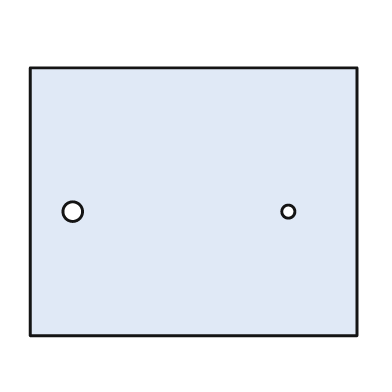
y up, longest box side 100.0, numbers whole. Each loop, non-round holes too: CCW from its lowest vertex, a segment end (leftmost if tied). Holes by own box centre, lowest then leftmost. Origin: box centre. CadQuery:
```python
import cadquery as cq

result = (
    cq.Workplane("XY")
    .moveTo(-50.0, -41.0)
    .lineTo(50.0, -41.0)
    .lineTo(50.0, 41.0)
    .lineTo(-50.0, 41.0)
    .close()
    .moveTo(-37.0, -3.0)
    .circle(3.0)
    .moveTo(29.0, -3.0)
    .circle(2.0)
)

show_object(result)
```